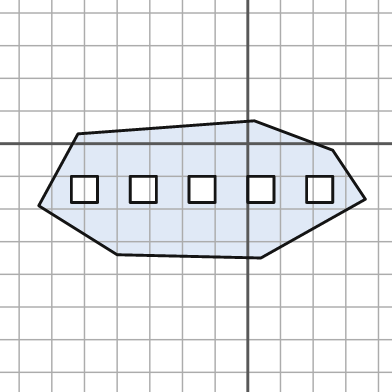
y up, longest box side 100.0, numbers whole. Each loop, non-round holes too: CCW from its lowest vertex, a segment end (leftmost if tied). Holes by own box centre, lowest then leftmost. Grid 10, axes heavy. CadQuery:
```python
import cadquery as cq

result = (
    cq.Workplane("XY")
    .moveTo(4.0, -35.0)
    .lineTo(36.0, -17.0)
    .lineTo(26.0, -2.0)
    .lineTo(2.0, 7.0)
    .lineTo(-52.0, 3.0)
    .lineTo(-64.0, -19.0)
    .lineTo(-40.0, -34.0)
    .close()
    .moveTo(-54.0, -18.0)
    .lineTo(-46.0, -18.0)
    .lineTo(-46.0, -10.0)
    .lineTo(-54.0, -10.0)
    .close()
    .moveTo(-36.0, -18.0)
    .lineTo(-28.0, -18.0)
    .lineTo(-28.0, -10.0)
    .lineTo(-36.0, -10.0)
    .close()
    .moveTo(-18.0, -18.0)
    .lineTo(-10.0, -18.0)
    .lineTo(-10.0, -10.0)
    .lineTo(-18.0, -10.0)
    .close()
    .moveTo(0.0, -18.0)
    .lineTo(8.0, -18.0)
    .lineTo(8.0, -10.0)
    .lineTo(0.0, -10.0)
    .close()
    .moveTo(18.0, -18.0)
    .lineTo(26.0, -18.0)
    .lineTo(26.0, -10.0)
    .lineTo(18.0, -10.0)
    .close()
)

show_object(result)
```